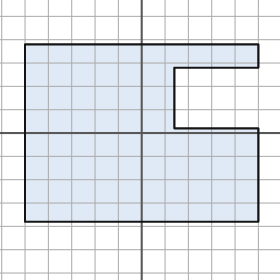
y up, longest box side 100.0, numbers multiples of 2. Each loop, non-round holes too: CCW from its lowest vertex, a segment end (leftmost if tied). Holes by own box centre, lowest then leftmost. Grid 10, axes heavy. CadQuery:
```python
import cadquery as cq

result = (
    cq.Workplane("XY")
    .moveTo(-50.0, -38.0)
    .lineTo(50.0, -38.0)
    .lineTo(50.0, 2.0)
    .lineTo(14.0, 2.0)
    .lineTo(14.0, 28.0)
    .lineTo(50.0, 28.0)
    .lineTo(50.0, 38.0)
    .lineTo(-50.0, 38.0)
    .close()
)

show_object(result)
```